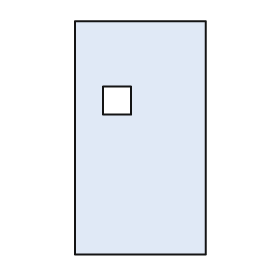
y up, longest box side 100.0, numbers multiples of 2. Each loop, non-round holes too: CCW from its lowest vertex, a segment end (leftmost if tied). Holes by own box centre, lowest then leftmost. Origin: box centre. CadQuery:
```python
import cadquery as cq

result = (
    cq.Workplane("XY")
    .moveTo(-28.0, -50.0)
    .lineTo(28.0, -50.0)
    .lineTo(28.0, 50.0)
    .lineTo(-28.0, 50.0)
    .close()
    .moveTo(-16.0, 10.0)
    .lineTo(-4.0, 10.0)
    .lineTo(-4.0, 22.0)
    .lineTo(-16.0, 22.0)
    .close()
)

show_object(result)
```